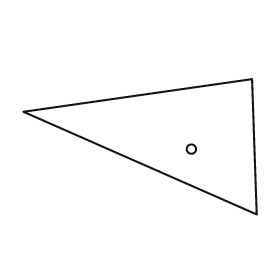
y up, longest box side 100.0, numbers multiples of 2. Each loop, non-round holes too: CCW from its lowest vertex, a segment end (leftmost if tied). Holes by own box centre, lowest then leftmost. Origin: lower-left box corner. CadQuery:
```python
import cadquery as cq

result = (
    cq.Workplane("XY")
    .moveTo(100.0, 0.0)
    .lineTo(98.0, 58.0)
    .lineTo(0.0, 44.0)
    .close()
    .moveTo(72.0, 28.0)
    .circle(2.0)
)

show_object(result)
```